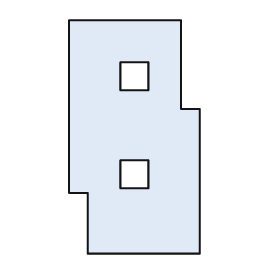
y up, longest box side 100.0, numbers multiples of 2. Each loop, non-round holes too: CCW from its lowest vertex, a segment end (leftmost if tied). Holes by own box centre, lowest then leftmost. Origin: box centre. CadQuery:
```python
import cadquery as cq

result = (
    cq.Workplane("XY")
    .moveTo(-20.0, -50.0)
    .lineTo(28.0, -50.0)
    .lineTo(28.0, 12.0)
    .lineTo(20.0, 12.0)
    .lineTo(20.0, 50.0)
    .lineTo(-28.0, 50.0)
    .lineTo(-28.0, -24.0)
    .lineTo(-20.0, -24.0)
    .close()
    .moveTo(-6.0, -22.0)
    .lineTo(6.0, -22.0)
    .lineTo(6.0, -10.0)
    .lineTo(-6.0, -10.0)
    .close()
    .moveTo(-6.0, 20.0)
    .lineTo(6.0, 20.0)
    .lineTo(6.0, 32.0)
    .lineTo(-6.0, 32.0)
    .close()
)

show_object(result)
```